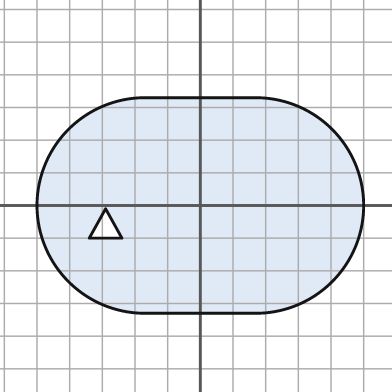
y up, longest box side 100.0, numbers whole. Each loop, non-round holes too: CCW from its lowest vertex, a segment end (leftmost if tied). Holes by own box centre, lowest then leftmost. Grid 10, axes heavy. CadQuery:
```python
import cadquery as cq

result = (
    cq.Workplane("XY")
    .moveTo(-17.0, -33.0)
    .lineTo(17.0, -33.0)
    .threePointArc((50.0, 0.0), (17.0, 33.0))
    .lineTo(-17.0, 33.0)
    .threePointArc((-50.0, 0.0), (-17.0, -33.0))
    .close()
    .moveTo(-34.0, -10.0)
    .lineTo(-24.0, -10.0)
    .lineTo(-29.0, -1.0)
    .close()
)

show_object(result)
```